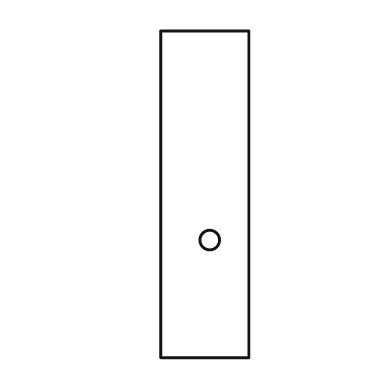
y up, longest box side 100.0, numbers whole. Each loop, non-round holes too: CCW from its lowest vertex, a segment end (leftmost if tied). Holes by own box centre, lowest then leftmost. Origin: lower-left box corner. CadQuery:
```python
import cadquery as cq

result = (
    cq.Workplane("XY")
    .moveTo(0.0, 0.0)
    .lineTo(27.0, 0.0)
    .lineTo(27.0, 100.0)
    .lineTo(0.0, 100.0)
    .close()
    .moveTo(15.0, 36.0)
    .circle(3.0)
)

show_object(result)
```